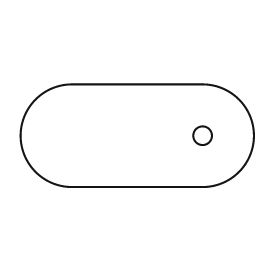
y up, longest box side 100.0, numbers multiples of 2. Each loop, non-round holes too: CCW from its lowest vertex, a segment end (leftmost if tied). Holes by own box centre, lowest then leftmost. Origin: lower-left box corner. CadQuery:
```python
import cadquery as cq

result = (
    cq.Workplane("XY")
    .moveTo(22.0, 0.0)
    .lineTo(78.0, 0.0)
    .threePointArc((100.0, 22.0), (78.0, 44.0))
    .lineTo(22.0, 44.0)
    .threePointArc((0.0, 22.0), (22.0, 0.0))
    .close()
    .moveTo(78.0, 22.0)
    .circle(4.0)
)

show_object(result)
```